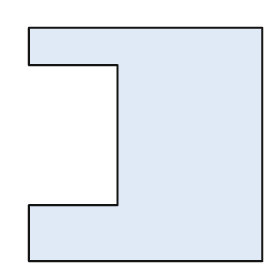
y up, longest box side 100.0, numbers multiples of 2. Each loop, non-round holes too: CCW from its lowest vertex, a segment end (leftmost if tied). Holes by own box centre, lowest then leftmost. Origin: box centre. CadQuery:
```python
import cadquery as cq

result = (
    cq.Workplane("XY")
    .moveTo(-50.0, -50.0)
    .lineTo(50.0, -50.0)
    .lineTo(50.0, 50.0)
    .lineTo(-50.0, 50.0)
    .lineTo(-50.0, 34.0)
    .lineTo(-12.0, 34.0)
    .lineTo(-12.0, -26.0)
    .lineTo(-50.0, -26.0)
    .close()
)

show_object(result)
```